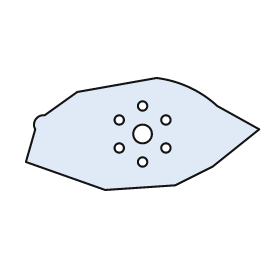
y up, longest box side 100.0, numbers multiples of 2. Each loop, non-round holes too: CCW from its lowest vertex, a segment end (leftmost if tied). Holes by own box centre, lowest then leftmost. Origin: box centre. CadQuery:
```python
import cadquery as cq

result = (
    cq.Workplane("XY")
    .moveTo(-16.0, -24.0)
    .lineTo(14.0, -22.0)
    .lineTo(30.0, -14.0)
    .lineTo(50.0, 2.0)
    .lineTo(32.0, 12.0)
    .threePointArc((20.0, 20.0), (6.0, 24.0))
    .lineTo(-28.0, 18.0)
    .lineTo(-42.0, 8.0)
    .threePointArc((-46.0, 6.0), (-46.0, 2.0))
    .lineTo(-50.0, -12.0)
    .close()
    .moveTo(0.0, -12.0)
    .circle(2.0)
    .moveTo(-10.0, -6.0)
    .circle(2.0)
    .moveTo(10.0, -6.0)
    .circle(2.0)
    .moveTo(0.0, 0.0)
    .circle(4.0)
    .moveTo(-10.0, 6.0)
    .circle(2.0)
    .moveTo(10.0, 6.0)
    .circle(2.0)
    .moveTo(0.0, 12.0)
    .circle(2.0)
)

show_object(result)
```